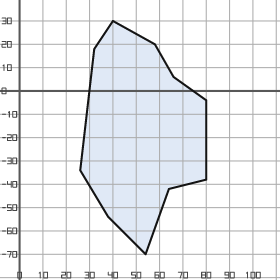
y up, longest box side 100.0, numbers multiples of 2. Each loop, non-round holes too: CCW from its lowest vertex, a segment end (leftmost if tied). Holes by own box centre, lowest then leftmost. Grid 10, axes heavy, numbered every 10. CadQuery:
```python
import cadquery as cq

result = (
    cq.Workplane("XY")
    .moveTo(54.0, -70.0)
    .lineTo(64.0, -42.0)
    .lineTo(80.0, -38.0)
    .lineTo(80.0, -4.0)
    .lineTo(66.0, 6.0)
    .lineTo(58.0, 20.0)
    .lineTo(40.0, 30.0)
    .lineTo(32.0, 18.0)
    .lineTo(26.0, -34.0)
    .lineTo(38.0, -54.0)
    .close()
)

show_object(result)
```